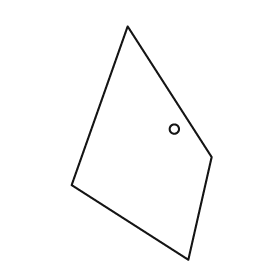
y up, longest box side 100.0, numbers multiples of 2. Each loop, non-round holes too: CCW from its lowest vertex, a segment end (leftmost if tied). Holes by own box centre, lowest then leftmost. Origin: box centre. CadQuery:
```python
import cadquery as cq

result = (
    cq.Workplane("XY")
    .moveTo(20.0, -50.0)
    .lineTo(30.0, -6.0)
    .lineTo(-6.0, 50.0)
    .lineTo(-30.0, -18.0)
    .close()
    .moveTo(14.0, 6.0)
    .circle(2.0)
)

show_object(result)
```